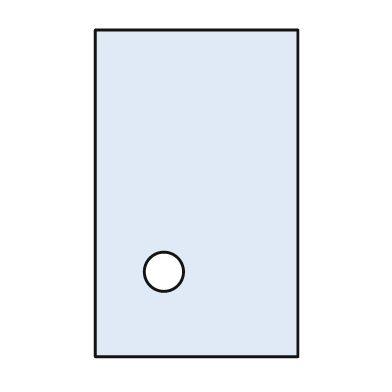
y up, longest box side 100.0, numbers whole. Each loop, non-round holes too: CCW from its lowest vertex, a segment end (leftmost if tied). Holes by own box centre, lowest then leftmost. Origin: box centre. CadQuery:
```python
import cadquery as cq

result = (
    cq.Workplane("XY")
    .moveTo(-31.0, -50.0)
    .lineTo(31.0, -50.0)
    .lineTo(31.0, 50.0)
    .lineTo(-31.0, 50.0)
    .close()
    .moveTo(-10.0, -24.0)
    .circle(6.0)
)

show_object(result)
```